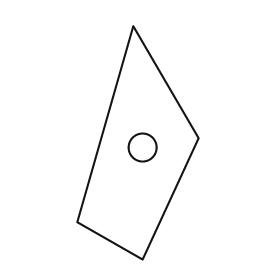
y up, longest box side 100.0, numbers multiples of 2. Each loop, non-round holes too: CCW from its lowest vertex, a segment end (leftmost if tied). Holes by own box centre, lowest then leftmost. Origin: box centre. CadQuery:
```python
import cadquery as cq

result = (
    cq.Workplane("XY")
    .moveTo(2.0, -50.0)
    .lineTo(26.0, 2.0)
    .lineTo(-2.0, 50.0)
    .lineTo(-26.0, -34.0)
    .close()
    .moveTo(2.0, -2.0)
    .circle(6.0)
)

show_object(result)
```